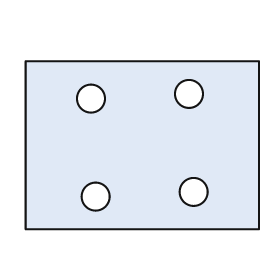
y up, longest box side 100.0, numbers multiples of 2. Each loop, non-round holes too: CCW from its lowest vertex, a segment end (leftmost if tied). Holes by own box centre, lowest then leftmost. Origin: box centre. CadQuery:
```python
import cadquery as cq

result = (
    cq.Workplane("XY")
    .moveTo(-50.0, -36.0)
    .lineTo(50.0, -36.0)
    .lineTo(50.0, 36.0)
    .lineTo(-50.0, 36.0)
    .close()
    .moveTo(-20.0, -22.0)
    .circle(6.0)
    .moveTo(22.0, -20.0)
    .circle(6.0)
    .moveTo(-22.0, 20.0)
    .circle(6.0)
    .moveTo(20.0, 22.0)
    .circle(6.0)
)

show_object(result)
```